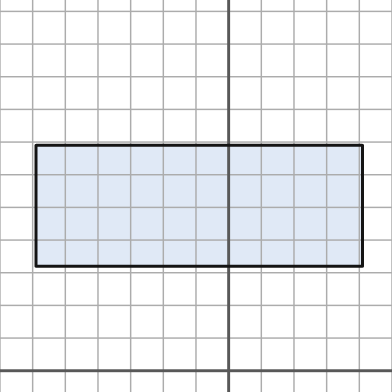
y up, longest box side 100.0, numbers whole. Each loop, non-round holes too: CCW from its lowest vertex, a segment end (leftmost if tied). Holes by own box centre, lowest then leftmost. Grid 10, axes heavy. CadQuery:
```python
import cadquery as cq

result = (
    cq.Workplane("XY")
    .moveTo(-59.0, 32.0)
    .lineTo(41.0, 32.0)
    .lineTo(41.0, 69.0)
    .lineTo(-59.0, 69.0)
    .close()
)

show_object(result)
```